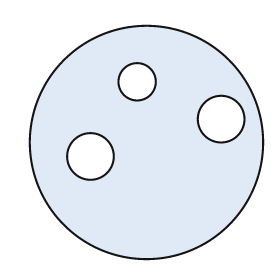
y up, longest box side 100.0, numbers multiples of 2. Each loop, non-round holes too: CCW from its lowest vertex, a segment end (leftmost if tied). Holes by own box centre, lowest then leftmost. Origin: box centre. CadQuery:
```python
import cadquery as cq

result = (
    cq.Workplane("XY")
    .moveTo(0.0, 0.0)
    .circle(50.0)
    .moveTo(-24.0, -6.0)
    .circle(10.0)
    .moveTo(32.0, 10.0)
    .circle(10.0)
    .moveTo(-4.0, 26.0)
    .circle(8.0)
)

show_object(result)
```